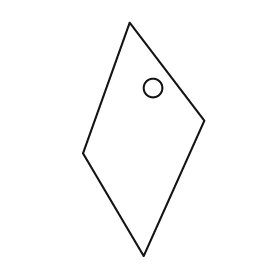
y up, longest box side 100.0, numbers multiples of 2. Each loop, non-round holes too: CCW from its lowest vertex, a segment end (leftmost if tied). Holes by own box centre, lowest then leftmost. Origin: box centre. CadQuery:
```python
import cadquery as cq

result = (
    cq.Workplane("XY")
    .moveTo(0.0, -50.0)
    .lineTo(26.0, 8.0)
    .lineTo(-6.0, 50.0)
    .lineTo(-26.0, -6.0)
    .close()
    .moveTo(4.0, 22.0)
    .circle(4.0)
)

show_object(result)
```